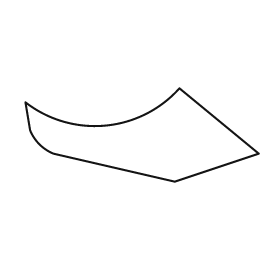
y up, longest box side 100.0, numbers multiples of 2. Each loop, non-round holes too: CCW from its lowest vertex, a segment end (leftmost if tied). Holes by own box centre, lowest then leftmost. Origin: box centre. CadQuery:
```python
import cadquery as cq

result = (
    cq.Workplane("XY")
    .moveTo(14.0, -20.0)
    .lineTo(50.0, -8.0)
    .lineTo(16.0, 20.0)
    .threePointArc((-16.0, 4.0), (-50.0, 14.0))
    .lineTo(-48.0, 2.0)
    .threePointArc((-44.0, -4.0), (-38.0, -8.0))
    .close()
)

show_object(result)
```